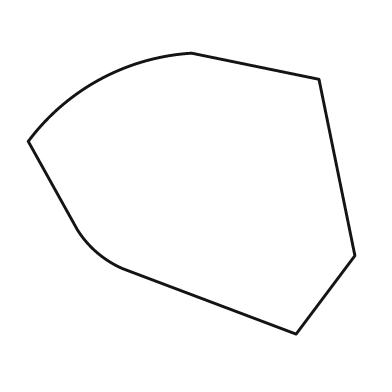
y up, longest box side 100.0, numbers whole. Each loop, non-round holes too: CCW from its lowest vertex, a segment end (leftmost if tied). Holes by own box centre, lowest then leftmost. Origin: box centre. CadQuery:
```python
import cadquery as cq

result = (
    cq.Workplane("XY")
    .moveTo(32.0, -43.0)
    .lineTo(50.0, -19.0)
    .lineTo(39.0, 35.0)
    .lineTo(0.0, 43.0)
    .threePointArc((-28.0, 35.0), (-50.0, 16.0))
    .lineTo(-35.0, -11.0)
    .threePointArc((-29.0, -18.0), (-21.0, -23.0))
    .close()
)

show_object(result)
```